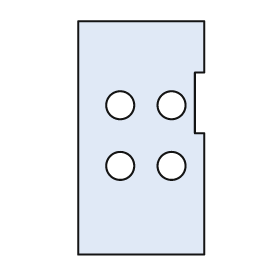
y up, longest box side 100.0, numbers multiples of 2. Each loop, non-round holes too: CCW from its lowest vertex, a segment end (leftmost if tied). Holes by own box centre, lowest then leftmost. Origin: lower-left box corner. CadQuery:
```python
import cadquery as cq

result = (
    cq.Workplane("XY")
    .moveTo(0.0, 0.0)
    .lineTo(54.0, 0.0)
    .lineTo(54.0, 52.0)
    .lineTo(50.0, 52.0)
    .lineTo(50.0, 78.0)
    .lineTo(54.0, 78.0)
    .lineTo(54.0, 100.0)
    .lineTo(0.0, 100.0)
    .close()
    .moveTo(18.0, 38.0)
    .circle(6.0)
    .moveTo(40.0, 38.0)
    .circle(6.0)
    .moveTo(18.0, 64.0)
    .circle(6.0)
    .moveTo(40.0, 64.0)
    .circle(6.0)
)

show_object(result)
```